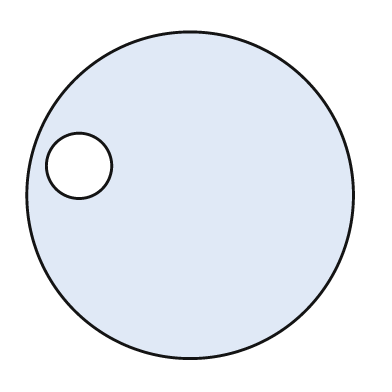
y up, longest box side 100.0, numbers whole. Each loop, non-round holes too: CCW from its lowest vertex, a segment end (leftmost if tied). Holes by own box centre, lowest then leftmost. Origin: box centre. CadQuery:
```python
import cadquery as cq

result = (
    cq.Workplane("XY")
    .moveTo(0.0, 0.0)
    .circle(50.0)
    .moveTo(-34.0, 9.0)
    .circle(10.0)
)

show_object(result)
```